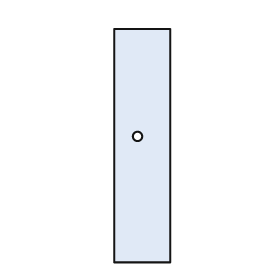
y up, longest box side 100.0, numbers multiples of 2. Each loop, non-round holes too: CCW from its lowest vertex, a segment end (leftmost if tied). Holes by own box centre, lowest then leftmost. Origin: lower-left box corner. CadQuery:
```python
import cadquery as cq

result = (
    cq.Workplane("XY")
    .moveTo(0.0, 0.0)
    .lineTo(24.0, 0.0)
    .lineTo(24.0, 100.0)
    .lineTo(0.0, 100.0)
    .close()
    .moveTo(10.0, 54.0)
    .circle(2.0)
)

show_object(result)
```